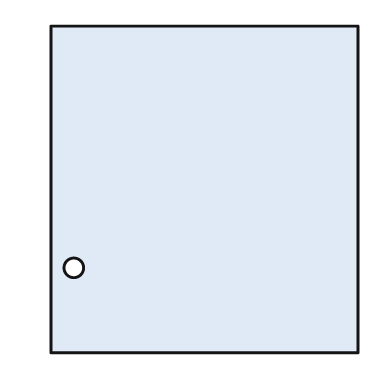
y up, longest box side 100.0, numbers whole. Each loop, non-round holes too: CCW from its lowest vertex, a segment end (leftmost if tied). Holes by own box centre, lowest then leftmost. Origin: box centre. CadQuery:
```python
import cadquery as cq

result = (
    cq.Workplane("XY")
    .moveTo(-47.0, -50.0)
    .lineTo(47.0, -50.0)
    .lineTo(47.0, 50.0)
    .lineTo(-47.0, 50.0)
    .close()
    .moveTo(-40.0, -24.0)
    .circle(3.0)
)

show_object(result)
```